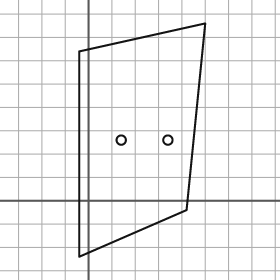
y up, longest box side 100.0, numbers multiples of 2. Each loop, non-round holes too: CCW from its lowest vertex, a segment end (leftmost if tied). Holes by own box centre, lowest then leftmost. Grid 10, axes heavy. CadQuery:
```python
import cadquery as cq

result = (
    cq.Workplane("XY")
    .moveTo(-4.0, -24.0)
    .lineTo(42.0, -4.0)
    .lineTo(50.0, 76.0)
    .lineTo(-4.0, 64.0)
    .close()
    .moveTo(14.0, 26.0)
    .circle(2.0)
    .moveTo(34.0, 26.0)
    .circle(2.0)
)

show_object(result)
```